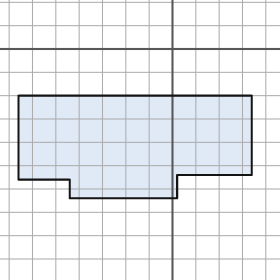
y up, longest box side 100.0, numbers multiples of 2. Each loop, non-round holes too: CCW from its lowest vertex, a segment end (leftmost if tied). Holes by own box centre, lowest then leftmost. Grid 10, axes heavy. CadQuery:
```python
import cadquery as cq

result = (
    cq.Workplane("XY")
    .moveTo(-44.0, -64.0)
    .lineTo(2.0, -64.0)
    .lineTo(2.0, -54.0)
    .lineTo(34.0, -54.0)
    .lineTo(34.0, -20.0)
    .lineTo(-66.0, -20.0)
    .lineTo(-66.0, -56.0)
    .lineTo(-44.0, -56.0)
    .close()
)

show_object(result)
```